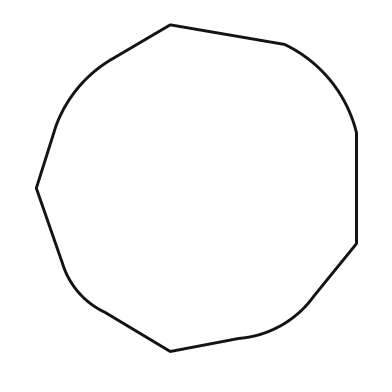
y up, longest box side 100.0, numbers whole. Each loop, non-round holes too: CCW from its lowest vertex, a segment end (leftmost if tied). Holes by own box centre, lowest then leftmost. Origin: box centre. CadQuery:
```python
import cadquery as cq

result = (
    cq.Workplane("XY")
    .moveTo(-8.0, -50.0)
    .lineTo(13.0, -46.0)
    .threePointArc((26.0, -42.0), (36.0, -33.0))
    .lineTo(49.0, -17.0)
    .lineTo(49.0, 17.0)
    .threePointArc((41.0, 33.0), (27.0, 44.0))
    .lineTo(-8.0, 50.0)
    .lineTo(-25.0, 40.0)
    .threePointArc((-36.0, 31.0), (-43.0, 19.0))
    .lineTo(-49.0, 0.0)
    .lineTo(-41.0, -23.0)
    .threePointArc((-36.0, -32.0), (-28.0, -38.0))
    .close()
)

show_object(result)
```